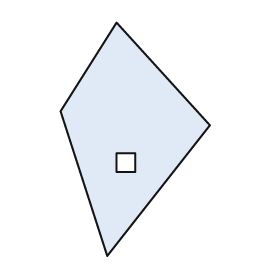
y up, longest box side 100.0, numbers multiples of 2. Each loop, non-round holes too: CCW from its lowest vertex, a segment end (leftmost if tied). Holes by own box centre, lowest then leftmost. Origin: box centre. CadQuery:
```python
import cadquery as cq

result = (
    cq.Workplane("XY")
    .moveTo(-12.0, -50.0)
    .lineTo(32.0, 6.0)
    .lineTo(-8.0, 50.0)
    .lineTo(-32.0, 12.0)
    .close()
    .moveTo(-8.0, -14.0)
    .lineTo(0.0, -14.0)
    .lineTo(0.0, -6.0)
    .lineTo(-8.0, -6.0)
    .close()
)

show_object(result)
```